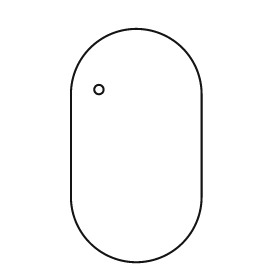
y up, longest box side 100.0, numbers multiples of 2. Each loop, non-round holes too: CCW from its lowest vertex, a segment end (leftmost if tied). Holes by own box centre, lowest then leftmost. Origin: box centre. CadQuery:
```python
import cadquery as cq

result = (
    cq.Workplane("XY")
    .moveTo(-28.0, -22.0)
    .threePointArc((0.0, -50.0), (28.0, -22.0))
    .lineTo(28.0, 22.0)
    .threePointArc((0.0, 50.0), (-28.0, 22.0))
    .close()
    .moveTo(-16.0, 24.0)
    .circle(2.0)
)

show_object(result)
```